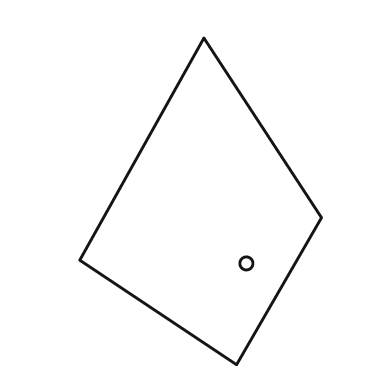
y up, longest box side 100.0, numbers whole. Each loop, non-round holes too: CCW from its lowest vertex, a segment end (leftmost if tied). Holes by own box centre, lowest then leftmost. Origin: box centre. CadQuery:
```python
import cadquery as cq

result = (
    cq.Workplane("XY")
    .moveTo(11.0, -50.0)
    .lineTo(37.0, -5.0)
    .lineTo(1.0, 50.0)
    .lineTo(-37.0, -18.0)
    .close()
    .moveTo(14.0, -19.0)
    .circle(2.0)
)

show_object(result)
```